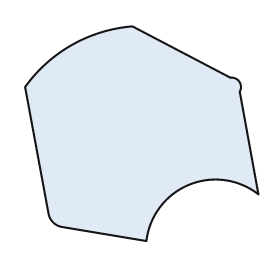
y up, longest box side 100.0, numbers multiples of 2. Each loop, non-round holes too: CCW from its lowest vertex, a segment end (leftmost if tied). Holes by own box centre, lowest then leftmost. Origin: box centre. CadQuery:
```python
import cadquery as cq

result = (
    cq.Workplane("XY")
    .moveTo(2.0, -46.0)
    .threePointArc((20.0, -22.0), (50.0, -26.0))
    .lineTo(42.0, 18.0)
    .threePointArc((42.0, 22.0), (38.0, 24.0))
    .lineTo(-4.0, 46.0)
    .threePointArc((-30.0, 38.0), (-50.0, 20.0))
    .lineTo(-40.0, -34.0)
    .threePointArc((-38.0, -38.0), (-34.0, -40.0))
    .close()
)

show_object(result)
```